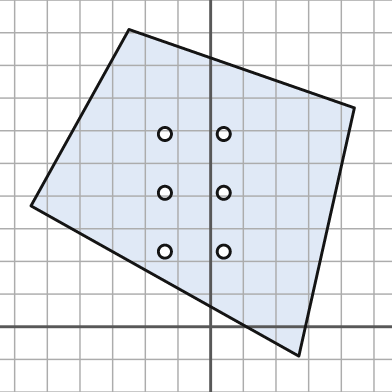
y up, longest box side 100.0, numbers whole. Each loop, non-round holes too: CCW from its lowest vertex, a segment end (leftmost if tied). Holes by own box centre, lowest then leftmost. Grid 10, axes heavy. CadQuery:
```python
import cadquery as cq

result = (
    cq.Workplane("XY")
    .moveTo(27.0, -9.0)
    .lineTo(44.0, 67.0)
    .lineTo(-25.0, 91.0)
    .lineTo(-55.0, 37.0)
    .close()
    .moveTo(-14.0, 23.0)
    .circle(2.0)
    .moveTo(4.0, 23.0)
    .circle(2.0)
    .moveTo(-14.0, 41.0)
    .circle(2.0)
    .moveTo(4.0, 41.0)
    .circle(2.0)
    .moveTo(-14.0, 59.0)
    .circle(2.0)
    .moveTo(4.0, 59.0)
    .circle(2.0)
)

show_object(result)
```